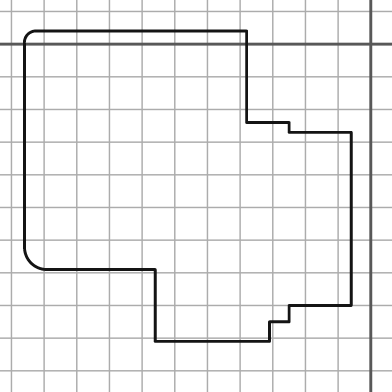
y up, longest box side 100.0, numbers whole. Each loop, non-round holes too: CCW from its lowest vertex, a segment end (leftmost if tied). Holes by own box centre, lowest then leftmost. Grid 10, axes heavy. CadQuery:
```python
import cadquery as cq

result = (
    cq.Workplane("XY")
    .moveTo(-66.0, -91.0)
    .lineTo(-31.0, -91.0)
    .lineTo(-31.0, -85.0)
    .lineTo(-25.0, -85.0)
    .lineTo(-25.0, -80.0)
    .lineTo(-6.0, -80.0)
    .lineTo(-6.0, -27.0)
    .lineTo(-25.0, -27.0)
    .lineTo(-25.0, -24.0)
    .lineTo(-38.0, -24.0)
    .lineTo(-38.0, 4.0)
    .lineTo(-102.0, 4.0)
    .threePointArc((-105.0, 3.0), (-106.0, 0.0))
    .lineTo(-106.0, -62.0)
    .threePointArc((-104.0, -67.0), (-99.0, -69.0))
    .lineTo(-66.0, -69.0)
    .close()
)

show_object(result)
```